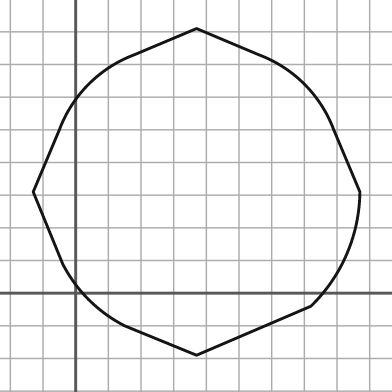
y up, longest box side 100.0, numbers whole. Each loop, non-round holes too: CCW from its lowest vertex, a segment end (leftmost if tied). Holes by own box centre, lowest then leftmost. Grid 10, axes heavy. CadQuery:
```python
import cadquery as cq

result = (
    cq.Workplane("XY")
    .moveTo(37.0, -19.0)
    .lineTo(72.0, -4.0)
    .threePointArc((83.0, 12.0), (87.0, 31.0))
    .lineTo(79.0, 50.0)
    .threePointArc((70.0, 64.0), (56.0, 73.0))
    .lineTo(37.0, 81.0)
    .lineTo(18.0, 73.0)
    .threePointArc((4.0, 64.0), (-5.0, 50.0))
    .lineTo(-13.0, 31.0)
    .lineTo(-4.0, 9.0)
    .threePointArc((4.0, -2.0), (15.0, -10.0))
    .close()
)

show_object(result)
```